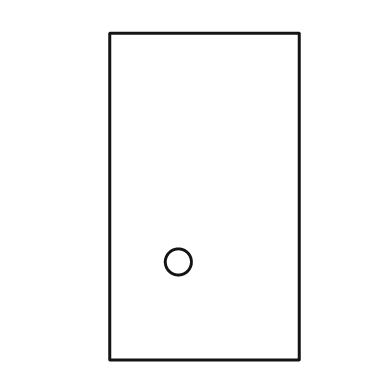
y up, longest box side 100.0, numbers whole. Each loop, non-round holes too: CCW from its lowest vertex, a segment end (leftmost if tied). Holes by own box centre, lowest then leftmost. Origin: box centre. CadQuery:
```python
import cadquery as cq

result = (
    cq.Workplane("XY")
    .moveTo(-29.0, -50.0)
    .lineTo(29.0, -50.0)
    .lineTo(29.0, 50.0)
    .lineTo(-29.0, 50.0)
    .close()
    .moveTo(-8.0, -20.0)
    .circle(4.0)
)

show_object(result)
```